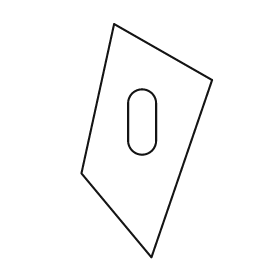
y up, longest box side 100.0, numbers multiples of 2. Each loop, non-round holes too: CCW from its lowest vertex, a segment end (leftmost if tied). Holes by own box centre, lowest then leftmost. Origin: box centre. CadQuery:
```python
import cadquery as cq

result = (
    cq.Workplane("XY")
    .moveTo(2.0, -50.0)
    .lineTo(28.0, 26.0)
    .lineTo(-14.0, 50.0)
    .lineTo(-28.0, -14.0)
    .close()
    .moveTo(-8.0, 0.0)
    .threePointArc((-2.0, -6.0), (4.0, 0.0))
    .lineTo(4.0, 16.0)
    .threePointArc((-2.0, 22.0), (-8.0, 16.0))
    .close()
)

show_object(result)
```